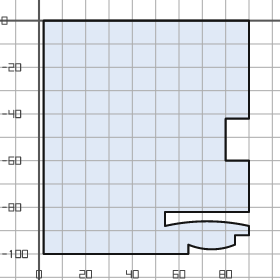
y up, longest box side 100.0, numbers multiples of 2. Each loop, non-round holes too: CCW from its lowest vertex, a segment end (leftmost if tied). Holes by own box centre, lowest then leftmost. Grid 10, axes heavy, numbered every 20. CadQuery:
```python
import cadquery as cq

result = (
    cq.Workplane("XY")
    .moveTo(2.0, -100.0)
    .lineTo(64.0, -100.0)
    .lineTo(64.0, -96.0)
    .threePointArc((74.0, -98.0), (84.0, -96.0))
    .lineTo(84.0, -92.0)
    .lineTo(90.0, -92.0)
    .lineTo(90.0, -88.0)
    .threePointArc((72.0, -86.0), (54.0, -88.0))
    .lineTo(54.0, -82.0)
    .lineTo(90.0, -82.0)
    .lineTo(90.0, -60.0)
    .lineTo(80.0, -60.0)
    .lineTo(80.0, -42.0)
    .lineTo(90.0, -42.0)
    .lineTo(90.0, 0.0)
    .lineTo(2.0, 0.0)
    .close()
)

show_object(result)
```